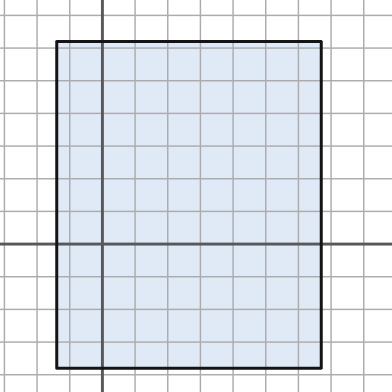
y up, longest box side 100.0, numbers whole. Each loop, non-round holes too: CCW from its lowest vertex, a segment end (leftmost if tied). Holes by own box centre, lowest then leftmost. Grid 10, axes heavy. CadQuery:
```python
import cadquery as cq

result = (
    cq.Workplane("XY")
    .moveTo(-14.0, -38.0)
    .lineTo(67.0, -38.0)
    .lineTo(67.0, 62.0)
    .lineTo(-14.0, 62.0)
    .close()
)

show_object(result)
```